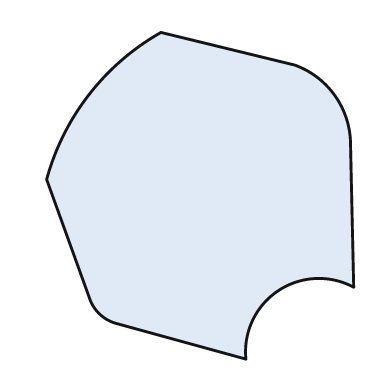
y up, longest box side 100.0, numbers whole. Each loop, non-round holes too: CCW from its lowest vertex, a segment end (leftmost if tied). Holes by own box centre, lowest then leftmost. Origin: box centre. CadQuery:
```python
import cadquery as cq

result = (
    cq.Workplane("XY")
    .moveTo(14.0, -50.0)
    .threePointArc((24.0, -29.0), (47.0, -28.0))
    .lineTo(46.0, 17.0)
    .threePointArc((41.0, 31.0), (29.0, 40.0))
    .lineTo(-12.0, 50.0)
    .threePointArc((-34.0, 31.0), (-47.0, 5.0))
    .lineTo(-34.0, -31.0)
    .threePointArc((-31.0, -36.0), (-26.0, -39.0))
    .close()
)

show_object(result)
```